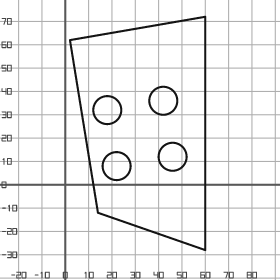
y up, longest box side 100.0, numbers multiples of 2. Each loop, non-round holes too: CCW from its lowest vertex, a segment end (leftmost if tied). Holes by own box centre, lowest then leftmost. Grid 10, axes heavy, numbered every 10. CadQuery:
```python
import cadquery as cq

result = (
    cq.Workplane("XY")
    .moveTo(60.0, -28.0)
    .lineTo(60.0, 72.0)
    .lineTo(2.0, 62.0)
    .lineTo(14.0, -12.0)
    .close()
    .moveTo(22.0, 8.0)
    .circle(6.0)
    .moveTo(46.0, 12.0)
    .circle(6.0)
    .moveTo(18.0, 32.0)
    .circle(6.0)
    .moveTo(42.0, 36.0)
    .circle(6.0)
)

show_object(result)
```